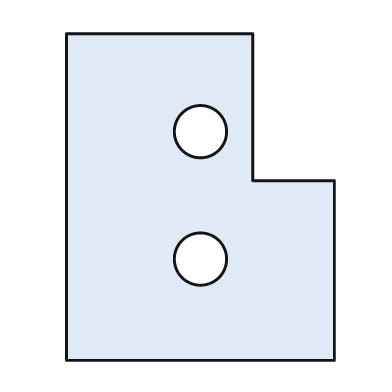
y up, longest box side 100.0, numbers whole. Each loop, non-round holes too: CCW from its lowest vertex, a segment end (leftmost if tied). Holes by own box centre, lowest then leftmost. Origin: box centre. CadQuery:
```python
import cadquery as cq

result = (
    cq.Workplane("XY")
    .moveTo(-41.0, -50.0)
    .lineTo(41.0, -50.0)
    .lineTo(41.0, 5.0)
    .lineTo(16.0, 5.0)
    .lineTo(16.0, 50.0)
    .lineTo(-41.0, 50.0)
    .close()
    .moveTo(0.0, -19.0)
    .circle(8.0)
    .moveTo(0.0, 20.0)
    .circle(8.0)
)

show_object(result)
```